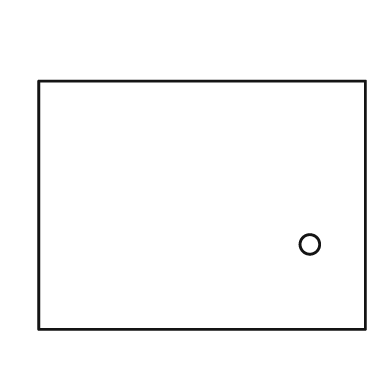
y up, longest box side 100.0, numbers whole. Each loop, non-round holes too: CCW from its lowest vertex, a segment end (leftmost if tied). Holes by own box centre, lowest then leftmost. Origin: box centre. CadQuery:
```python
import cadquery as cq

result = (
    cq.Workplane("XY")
    .moveTo(-50.0, -38.0)
    .lineTo(50.0, -38.0)
    .lineTo(50.0, 38.0)
    .lineTo(-50.0, 38.0)
    .close()
    .moveTo(33.0, -12.0)
    .circle(3.0)
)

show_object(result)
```